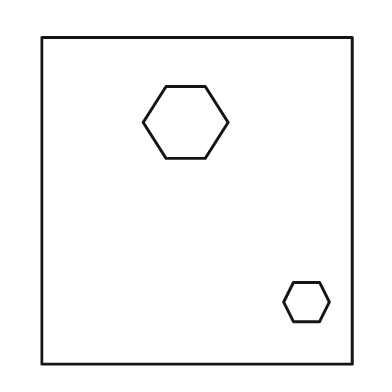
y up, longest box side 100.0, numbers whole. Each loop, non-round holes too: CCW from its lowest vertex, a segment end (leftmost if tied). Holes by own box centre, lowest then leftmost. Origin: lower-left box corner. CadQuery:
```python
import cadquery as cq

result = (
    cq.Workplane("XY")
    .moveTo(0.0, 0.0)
    .lineTo(95.0, 0.0)
    .lineTo(95.0, 100.0)
    .lineTo(0.0, 100.0)
    .close()
    .moveTo(77.0, 13.0)
    .lineTo(85.0, 13.0)
    .lineTo(88.0, 19.0)
    .lineTo(85.0, 25.0)
    .lineTo(77.0, 25.0)
    .lineTo(74.0, 19.0)
    .close()
    .moveTo(38.0, 63.0)
    .lineTo(50.0, 63.0)
    .lineTo(57.0, 74.0)
    .lineTo(50.0, 85.0)
    .lineTo(38.0, 85.0)
    .lineTo(31.0, 74.0)
    .close()
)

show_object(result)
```